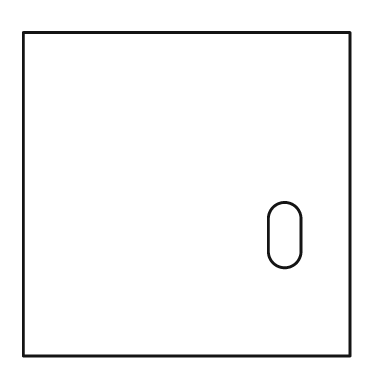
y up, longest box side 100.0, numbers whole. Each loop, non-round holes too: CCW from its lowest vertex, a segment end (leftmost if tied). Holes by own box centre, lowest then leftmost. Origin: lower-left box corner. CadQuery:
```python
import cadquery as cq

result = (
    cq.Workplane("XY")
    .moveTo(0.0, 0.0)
    .lineTo(100.0, 0.0)
    .lineTo(100.0, 99.0)
    .lineTo(0.0, 99.0)
    .close()
    .moveTo(75.0, 32.0)
    .threePointArc((80.0, 27.0), (85.0, 32.0))
    .lineTo(85.0, 42.0)
    .threePointArc((80.0, 47.0), (75.0, 42.0))
    .close()
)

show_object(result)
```